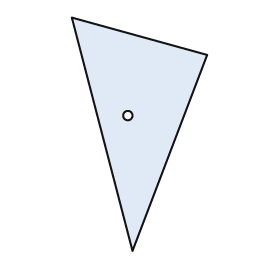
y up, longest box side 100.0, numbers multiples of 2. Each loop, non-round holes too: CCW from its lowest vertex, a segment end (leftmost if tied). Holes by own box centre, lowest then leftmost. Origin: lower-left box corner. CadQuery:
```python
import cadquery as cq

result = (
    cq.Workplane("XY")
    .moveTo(26.0, 0.0)
    .lineTo(58.0, 84.0)
    .lineTo(0.0, 100.0)
    .close()
    .moveTo(24.0, 58.0)
    .circle(2.0)
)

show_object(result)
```